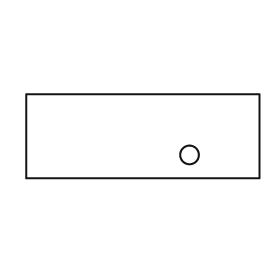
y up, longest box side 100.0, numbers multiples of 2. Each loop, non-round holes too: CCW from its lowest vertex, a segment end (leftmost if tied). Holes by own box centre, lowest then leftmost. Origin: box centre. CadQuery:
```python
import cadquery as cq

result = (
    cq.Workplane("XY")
    .moveTo(-50.0, -18.0)
    .lineTo(50.0, -18.0)
    .lineTo(50.0, 18.0)
    .lineTo(-50.0, 18.0)
    .close()
    .moveTo(20.0, -8.0)
    .circle(4.0)
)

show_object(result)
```